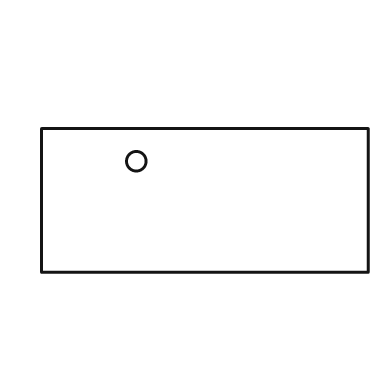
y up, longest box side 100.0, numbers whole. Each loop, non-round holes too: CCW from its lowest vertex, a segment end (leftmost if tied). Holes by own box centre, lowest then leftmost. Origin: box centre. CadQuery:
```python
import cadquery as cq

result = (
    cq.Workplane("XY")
    .moveTo(-50.0, -22.0)
    .lineTo(50.0, -22.0)
    .lineTo(50.0, 22.0)
    .lineTo(-50.0, 22.0)
    .close()
    .moveTo(-21.0, 12.0)
    .circle(3.0)
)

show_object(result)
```